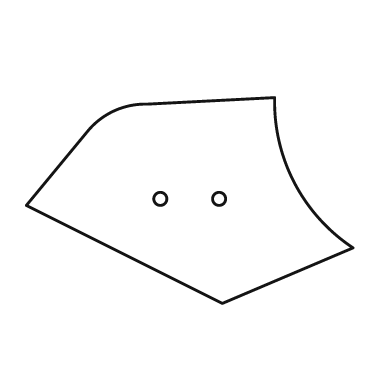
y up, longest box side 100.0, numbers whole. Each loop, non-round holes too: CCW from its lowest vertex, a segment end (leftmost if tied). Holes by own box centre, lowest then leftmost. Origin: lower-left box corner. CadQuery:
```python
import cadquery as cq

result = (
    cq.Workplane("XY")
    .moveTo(60.0, 0.0)
    .lineTo(100.0, 17.0)
    .threePointArc((82.0, 37.0), (76.0, 63.0))
    .lineTo(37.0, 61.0)
    .threePointArc((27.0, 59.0), (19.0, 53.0))
    .lineTo(0.0, 30.0)
    .close()
    .moveTo(41.0, 32.0)
    .circle(2.0)
    .moveTo(59.0, 32.0)
    .circle(2.0)
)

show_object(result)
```